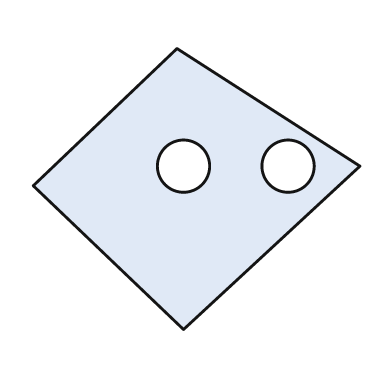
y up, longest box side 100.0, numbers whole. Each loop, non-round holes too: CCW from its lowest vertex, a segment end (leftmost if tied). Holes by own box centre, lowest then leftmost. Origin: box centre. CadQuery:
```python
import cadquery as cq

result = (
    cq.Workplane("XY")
    .moveTo(-4.0, -43.0)
    .lineTo(50.0, 7.0)
    .lineTo(-6.0, 43.0)
    .lineTo(-50.0, 1.0)
    .close()
    .moveTo(-4.0, 7.0)
    .circle(8.0)
    .moveTo(28.0, 7.0)
    .circle(8.0)
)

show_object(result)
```